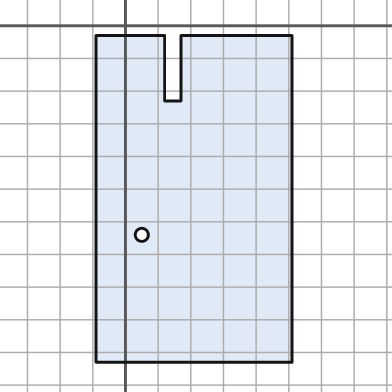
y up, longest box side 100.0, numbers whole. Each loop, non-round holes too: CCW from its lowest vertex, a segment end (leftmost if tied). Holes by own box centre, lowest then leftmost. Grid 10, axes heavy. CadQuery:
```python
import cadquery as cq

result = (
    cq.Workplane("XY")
    .moveTo(-9.0, -103.0)
    .lineTo(51.0, -103.0)
    .lineTo(51.0, -3.0)
    .lineTo(17.0, -3.0)
    .lineTo(17.0, -23.0)
    .lineTo(12.0, -23.0)
    .lineTo(12.0, -3.0)
    .lineTo(-9.0, -3.0)
    .close()
    .moveTo(5.0, -64.0)
    .circle(2.0)
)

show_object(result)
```